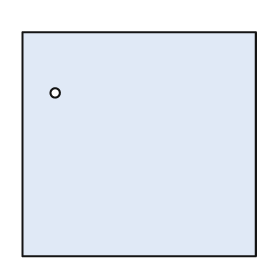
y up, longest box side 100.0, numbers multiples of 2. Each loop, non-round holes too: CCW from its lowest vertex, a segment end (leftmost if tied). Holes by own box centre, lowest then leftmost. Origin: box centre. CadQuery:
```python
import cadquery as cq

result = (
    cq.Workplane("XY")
    .moveTo(-50.0, -48.0)
    .lineTo(50.0, -48.0)
    .lineTo(50.0, 48.0)
    .lineTo(-50.0, 48.0)
    .close()
    .moveTo(-36.0, 22.0)
    .circle(2.0)
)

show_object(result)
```